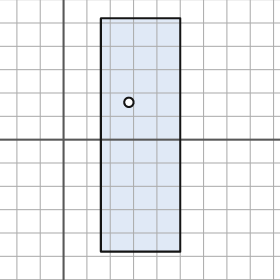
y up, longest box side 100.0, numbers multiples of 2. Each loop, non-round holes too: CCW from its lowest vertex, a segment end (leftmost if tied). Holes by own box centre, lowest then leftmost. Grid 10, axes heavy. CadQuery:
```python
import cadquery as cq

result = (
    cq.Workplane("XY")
    .moveTo(16.0, -48.0)
    .lineTo(50.0, -48.0)
    .lineTo(50.0, 52.0)
    .lineTo(16.0, 52.0)
    .close()
    .moveTo(28.0, 16.0)
    .circle(2.0)
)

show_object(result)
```